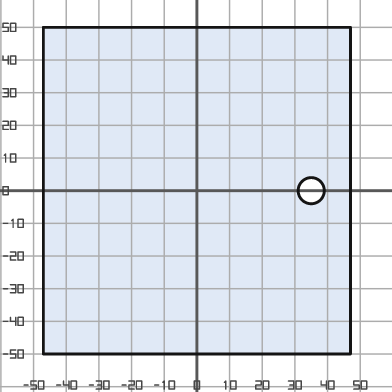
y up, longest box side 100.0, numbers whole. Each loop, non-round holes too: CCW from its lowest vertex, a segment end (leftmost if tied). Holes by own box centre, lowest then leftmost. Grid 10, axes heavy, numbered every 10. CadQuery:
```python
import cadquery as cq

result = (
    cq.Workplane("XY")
    .moveTo(-47.0, -50.0)
    .lineTo(47.0, -50.0)
    .lineTo(47.0, 50.0)
    .lineTo(-47.0, 50.0)
    .close()
    .moveTo(35.0, 0.0)
    .circle(4.0)
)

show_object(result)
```